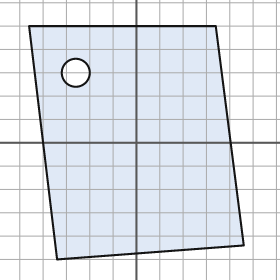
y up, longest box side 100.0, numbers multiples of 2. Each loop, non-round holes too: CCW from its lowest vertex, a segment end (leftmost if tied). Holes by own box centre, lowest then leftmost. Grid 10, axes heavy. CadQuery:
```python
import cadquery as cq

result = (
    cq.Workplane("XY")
    .moveTo(-34.0, -50.0)
    .lineTo(46.0, -44.0)
    .lineTo(34.0, 50.0)
    .lineTo(-46.0, 50.0)
    .close()
    .moveTo(-26.0, 30.0)
    .circle(6.0)
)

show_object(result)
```